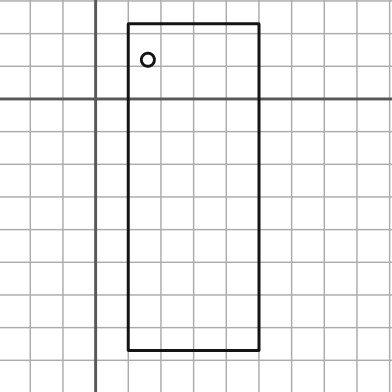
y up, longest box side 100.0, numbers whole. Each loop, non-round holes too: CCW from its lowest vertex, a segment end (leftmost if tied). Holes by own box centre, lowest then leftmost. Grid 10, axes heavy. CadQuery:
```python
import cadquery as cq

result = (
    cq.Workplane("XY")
    .moveTo(10.0, -77.0)
    .lineTo(50.0, -77.0)
    .lineTo(50.0, 23.0)
    .lineTo(10.0, 23.0)
    .close()
    .moveTo(16.0, 12.0)
    .circle(2.0)
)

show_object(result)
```